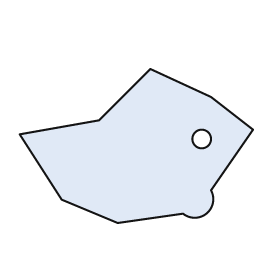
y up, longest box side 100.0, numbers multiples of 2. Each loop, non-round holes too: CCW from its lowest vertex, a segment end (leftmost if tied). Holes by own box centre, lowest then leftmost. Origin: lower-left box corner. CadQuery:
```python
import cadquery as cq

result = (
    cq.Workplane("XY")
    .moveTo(42.0, 0.0)
    .lineTo(70.0, 4.0)
    .threePointArc((80.0, 4.0), (82.0, 14.0))
    .lineTo(100.0, 40.0)
    .lineTo(82.0, 54.0)
    .lineTo(56.0, 66.0)
    .lineTo(34.0, 44.0)
    .lineTo(0.0, 38.0)
    .lineTo(18.0, 10.0)
    .close()
    .moveTo(78.0, 36.0)
    .circle(4.0)
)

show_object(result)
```